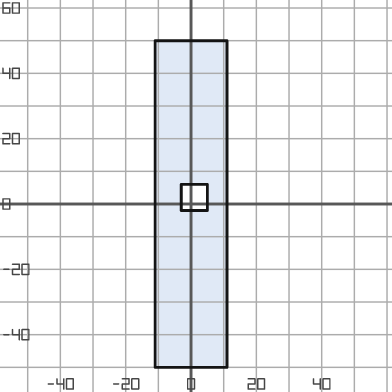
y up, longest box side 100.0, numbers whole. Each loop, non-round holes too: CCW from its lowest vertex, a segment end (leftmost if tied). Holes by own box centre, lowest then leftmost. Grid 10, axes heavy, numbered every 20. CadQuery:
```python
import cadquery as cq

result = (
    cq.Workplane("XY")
    .moveTo(-11.0, -50.0)
    .lineTo(11.0, -50.0)
    .lineTo(11.0, 50.0)
    .lineTo(-11.0, 50.0)
    .close()
    .moveTo(-3.0, -2.0)
    .lineTo(5.0, -2.0)
    .lineTo(5.0, 6.0)
    .lineTo(-3.0, 6.0)
    .close()
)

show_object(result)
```